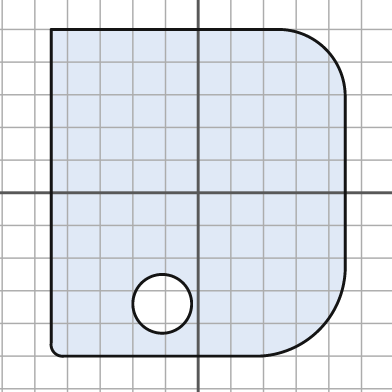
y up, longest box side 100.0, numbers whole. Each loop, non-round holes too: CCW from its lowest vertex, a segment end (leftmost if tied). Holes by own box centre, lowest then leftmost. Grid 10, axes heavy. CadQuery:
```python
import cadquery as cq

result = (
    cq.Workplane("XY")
    .moveTo(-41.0, -50.0)
    .lineTo(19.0, -50.0)
    .threePointArc((37.0, -42.0), (45.0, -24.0))
    .lineTo(45.0, 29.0)
    .threePointArc((39.0, 44.0), (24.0, 50.0))
    .lineTo(-45.0, 50.0)
    .lineTo(-45.0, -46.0)
    .threePointArc((-44.0, -49.0), (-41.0, -50.0))
    .close()
    .moveTo(-11.0, -34.0)
    .circle(9.0)
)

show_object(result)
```